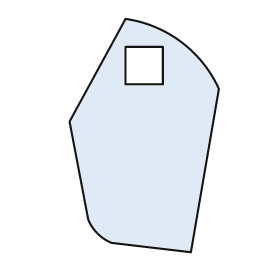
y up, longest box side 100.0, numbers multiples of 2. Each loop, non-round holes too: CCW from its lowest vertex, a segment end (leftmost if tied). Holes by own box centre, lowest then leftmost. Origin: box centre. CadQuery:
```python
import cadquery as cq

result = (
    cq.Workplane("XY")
    .moveTo(20.0, -50.0)
    .lineTo(32.0, 20.0)
    .threePointArc((16.0, 40.0), (-8.0, 50.0))
    .lineTo(-32.0, 6.0)
    .lineTo(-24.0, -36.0)
    .threePointArc((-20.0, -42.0), (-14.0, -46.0))
    .close()
    .moveTo(-8.0, 22.0)
    .lineTo(8.0, 22.0)
    .lineTo(8.0, 38.0)
    .lineTo(-8.0, 38.0)
    .close()
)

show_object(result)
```